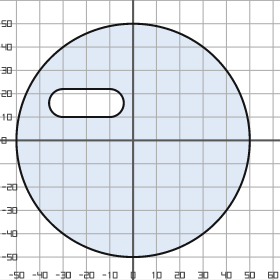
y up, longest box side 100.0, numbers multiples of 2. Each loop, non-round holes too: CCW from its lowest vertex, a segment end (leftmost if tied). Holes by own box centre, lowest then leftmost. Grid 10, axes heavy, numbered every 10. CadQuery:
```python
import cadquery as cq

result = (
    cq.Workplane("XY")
    .moveTo(0.0, 0.0)
    .circle(50.0)
    .moveTo(-30.0, 10.0)
    .lineTo(-10.0, 10.0)
    .threePointArc((-4.0, 16.0), (-10.0, 22.0))
    .lineTo(-30.0, 22.0)
    .threePointArc((-36.0, 16.0), (-30.0, 10.0))
    .close()
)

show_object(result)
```